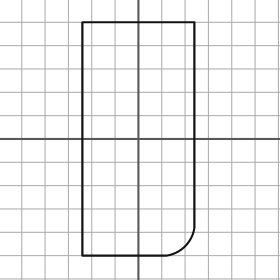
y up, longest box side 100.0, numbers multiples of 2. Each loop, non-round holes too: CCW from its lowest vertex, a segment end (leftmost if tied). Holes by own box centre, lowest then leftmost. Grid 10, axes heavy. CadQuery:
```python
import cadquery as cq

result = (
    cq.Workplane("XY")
    .moveTo(-24.0, -50.0)
    .lineTo(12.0, -50.0)
    .threePointArc((20.0, -46.0), (24.0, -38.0))
    .lineTo(24.0, 50.0)
    .lineTo(-24.0, 50.0)
    .close()
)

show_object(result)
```